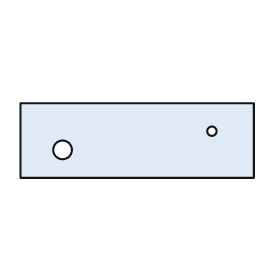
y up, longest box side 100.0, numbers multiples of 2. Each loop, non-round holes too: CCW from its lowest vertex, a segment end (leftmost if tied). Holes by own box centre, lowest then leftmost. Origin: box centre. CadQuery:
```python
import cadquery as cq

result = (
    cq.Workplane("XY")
    .moveTo(-50.0, -16.0)
    .lineTo(50.0, -16.0)
    .lineTo(50.0, 16.0)
    .lineTo(-50.0, 16.0)
    .close()
    .moveTo(-32.0, -4.0)
    .circle(4.0)
    .moveTo(32.0, 4.0)
    .circle(2.0)
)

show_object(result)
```